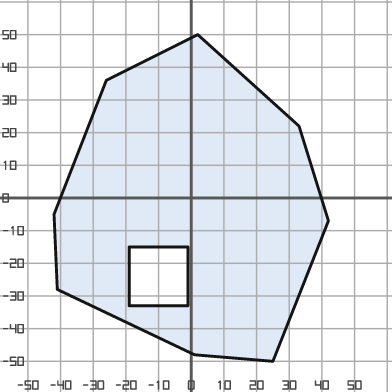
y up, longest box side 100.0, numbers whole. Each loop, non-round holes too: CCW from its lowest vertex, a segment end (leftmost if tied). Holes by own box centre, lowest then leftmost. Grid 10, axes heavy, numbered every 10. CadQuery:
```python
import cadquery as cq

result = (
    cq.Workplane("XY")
    .moveTo(25.0, -50.0)
    .lineTo(42.0, -7.0)
    .lineTo(33.0, 22.0)
    .lineTo(2.0, 50.0)
    .lineTo(-26.0, 36.0)
    .lineTo(-42.0, -5.0)
    .lineTo(-41.0, -28.0)
    .lineTo(1.0, -48.0)
    .close()
    .moveTo(-19.0, -33.0)
    .lineTo(-1.0, -33.0)
    .lineTo(-1.0, -15.0)
    .lineTo(-19.0, -15.0)
    .close()
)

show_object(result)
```